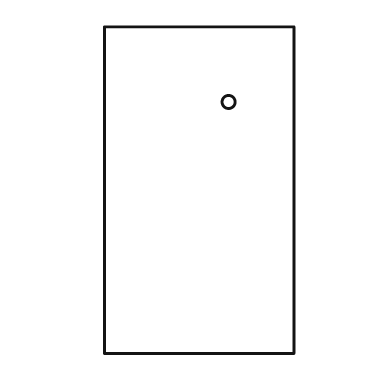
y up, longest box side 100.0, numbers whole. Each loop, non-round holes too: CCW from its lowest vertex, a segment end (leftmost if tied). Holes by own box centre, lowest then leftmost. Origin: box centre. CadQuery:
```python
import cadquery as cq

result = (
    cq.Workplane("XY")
    .moveTo(-29.0, -50.0)
    .lineTo(29.0, -50.0)
    .lineTo(29.0, 50.0)
    .lineTo(-29.0, 50.0)
    .close()
    .moveTo(9.0, 27.0)
    .circle(2.0)
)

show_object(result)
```